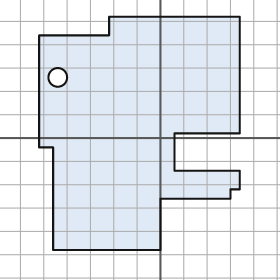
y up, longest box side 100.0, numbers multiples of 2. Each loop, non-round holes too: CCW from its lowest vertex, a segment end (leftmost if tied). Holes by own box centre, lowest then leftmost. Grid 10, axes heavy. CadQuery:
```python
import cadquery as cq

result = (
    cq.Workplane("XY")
    .moveTo(-46.0, -48.0)
    .lineTo(0.0, -48.0)
    .lineTo(0.0, -26.0)
    .lineTo(30.0, -26.0)
    .lineTo(30.0, -22.0)
    .lineTo(34.0, -22.0)
    .lineTo(34.0, -14.0)
    .lineTo(6.0, -14.0)
    .lineTo(6.0, 2.0)
    .lineTo(34.0, 2.0)
    .lineTo(34.0, 52.0)
    .lineTo(-22.0, 52.0)
    .lineTo(-22.0, 44.0)
    .lineTo(-52.0, 44.0)
    .lineTo(-52.0, -4.0)
    .lineTo(-46.0, -4.0)
    .close()
    .moveTo(-44.0, 26.0)
    .circle(4.0)
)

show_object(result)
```